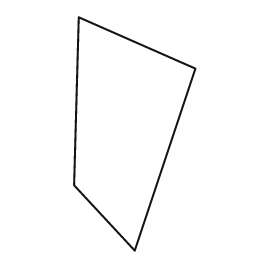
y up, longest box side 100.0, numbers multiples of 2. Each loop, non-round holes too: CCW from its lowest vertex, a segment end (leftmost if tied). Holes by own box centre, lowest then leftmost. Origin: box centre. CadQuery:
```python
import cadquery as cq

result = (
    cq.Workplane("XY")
    .moveTo(0.0, -50.0)
    .lineTo(26.0, 28.0)
    .lineTo(-24.0, 50.0)
    .lineTo(-26.0, -22.0)
    .close()
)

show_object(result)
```